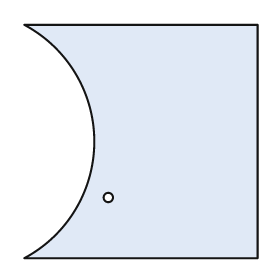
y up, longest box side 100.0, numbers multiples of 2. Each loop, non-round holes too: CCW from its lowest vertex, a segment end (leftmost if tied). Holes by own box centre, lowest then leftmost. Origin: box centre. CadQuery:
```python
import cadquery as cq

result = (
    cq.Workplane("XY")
    .moveTo(-50.0, -50.0)
    .lineTo(50.0, -50.0)
    .lineTo(50.0, 50.0)
    .lineTo(-50.0, 50.0)
    .threePointArc((-20.0, 0.0), (-50.0, -50.0))
    .close()
    .moveTo(-14.0, -24.0)
    .circle(2.0)
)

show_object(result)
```